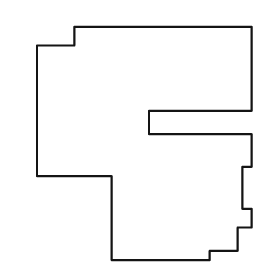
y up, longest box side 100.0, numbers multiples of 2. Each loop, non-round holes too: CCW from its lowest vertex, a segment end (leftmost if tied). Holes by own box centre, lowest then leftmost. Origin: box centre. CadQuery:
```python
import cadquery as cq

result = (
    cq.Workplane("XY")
    .moveTo(-14.0, -50.0)
    .lineTo(28.0, -50.0)
    .lineTo(28.0, -46.0)
    .lineTo(40.0, -46.0)
    .lineTo(40.0, -36.0)
    .lineTo(46.0, -36.0)
    .lineTo(46.0, -28.0)
    .lineTo(42.0, -28.0)
    .lineTo(42.0, -10.0)
    .lineTo(46.0, -10.0)
    .lineTo(46.0, 4.0)
    .lineTo(2.0, 4.0)
    .lineTo(2.0, 14.0)
    .lineTo(46.0, 14.0)
    .lineTo(46.0, 50.0)
    .lineTo(-30.0, 50.0)
    .lineTo(-30.0, 42.0)
    .lineTo(-46.0, 42.0)
    .lineTo(-46.0, -14.0)
    .lineTo(-14.0, -14.0)
    .close()
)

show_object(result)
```